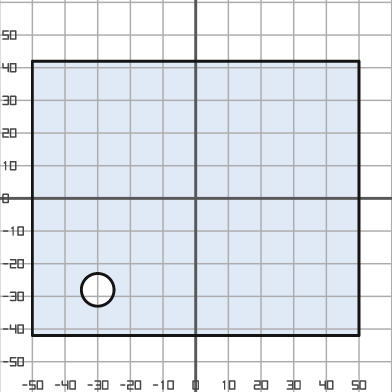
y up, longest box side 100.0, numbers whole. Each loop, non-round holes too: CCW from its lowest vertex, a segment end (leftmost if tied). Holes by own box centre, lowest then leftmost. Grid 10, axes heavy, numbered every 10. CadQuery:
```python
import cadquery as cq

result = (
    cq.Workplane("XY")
    .moveTo(-50.0, -42.0)
    .lineTo(50.0, -42.0)
    .lineTo(50.0, 42.0)
    .lineTo(-50.0, 42.0)
    .close()
    .moveTo(-30.0, -28.0)
    .circle(5.0)
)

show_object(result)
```